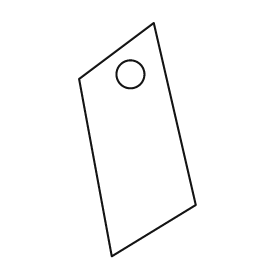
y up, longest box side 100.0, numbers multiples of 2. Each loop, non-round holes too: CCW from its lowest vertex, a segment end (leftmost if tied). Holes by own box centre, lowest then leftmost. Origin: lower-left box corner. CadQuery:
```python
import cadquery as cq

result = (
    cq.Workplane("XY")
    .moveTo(14.0, 0.0)
    .lineTo(50.0, 22.0)
    .lineTo(32.0, 100.0)
    .lineTo(0.0, 76.0)
    .close()
    .moveTo(22.0, 78.0)
    .circle(6.0)
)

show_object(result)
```